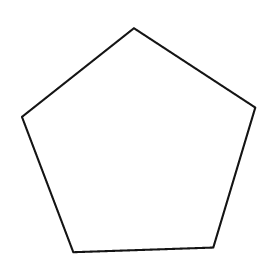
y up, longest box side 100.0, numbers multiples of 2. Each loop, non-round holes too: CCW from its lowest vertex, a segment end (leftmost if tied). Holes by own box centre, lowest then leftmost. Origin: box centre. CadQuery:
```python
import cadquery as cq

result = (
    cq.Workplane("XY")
    .moveTo(-28.0, -48.0)
    .lineTo(32.0, -46.0)
    .lineTo(50.0, 14.0)
    .lineTo(-2.0, 48.0)
    .lineTo(-50.0, 10.0)
    .close()
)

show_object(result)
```